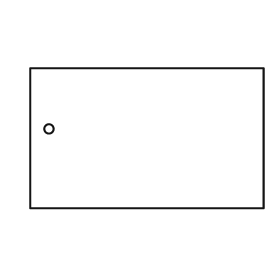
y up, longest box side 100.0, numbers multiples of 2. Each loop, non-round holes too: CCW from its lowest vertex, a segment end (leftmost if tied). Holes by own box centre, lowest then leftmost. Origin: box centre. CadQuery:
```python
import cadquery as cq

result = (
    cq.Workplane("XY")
    .moveTo(-50.0, -30.0)
    .lineTo(50.0, -30.0)
    .lineTo(50.0, 30.0)
    .lineTo(-50.0, 30.0)
    .close()
    .moveTo(-42.0, 4.0)
    .circle(2.0)
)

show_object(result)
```